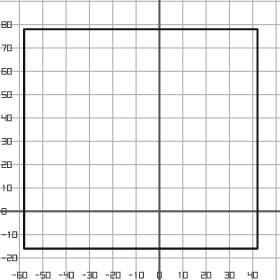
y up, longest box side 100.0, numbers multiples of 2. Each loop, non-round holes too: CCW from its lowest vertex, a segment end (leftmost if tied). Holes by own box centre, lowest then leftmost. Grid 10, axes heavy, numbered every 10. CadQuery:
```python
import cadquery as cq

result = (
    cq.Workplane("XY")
    .moveTo(-58.0, -16.0)
    .lineTo(42.0, -16.0)
    .lineTo(42.0, 78.0)
    .lineTo(-58.0, 78.0)
    .close()
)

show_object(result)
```